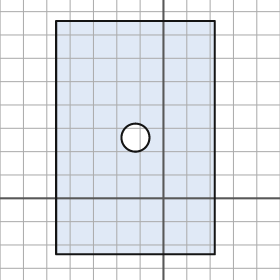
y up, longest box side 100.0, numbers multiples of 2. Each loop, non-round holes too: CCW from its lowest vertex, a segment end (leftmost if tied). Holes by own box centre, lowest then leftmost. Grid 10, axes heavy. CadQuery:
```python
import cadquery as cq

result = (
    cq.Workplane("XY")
    .moveTo(-46.0, -24.0)
    .lineTo(22.0, -24.0)
    .lineTo(22.0, 76.0)
    .lineTo(-46.0, 76.0)
    .close()
    .moveTo(-12.0, 26.0)
    .circle(6.0)
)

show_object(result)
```